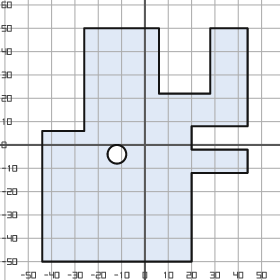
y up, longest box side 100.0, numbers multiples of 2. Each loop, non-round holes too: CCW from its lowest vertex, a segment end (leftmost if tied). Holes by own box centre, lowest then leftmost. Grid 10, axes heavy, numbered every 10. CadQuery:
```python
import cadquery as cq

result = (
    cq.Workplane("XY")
    .moveTo(-44.0, -50.0)
    .lineTo(20.0, -50.0)
    .lineTo(20.0, -12.0)
    .lineTo(44.0, -12.0)
    .lineTo(44.0, -2.0)
    .lineTo(20.0, -2.0)
    .lineTo(20.0, 8.0)
    .lineTo(44.0, 8.0)
    .lineTo(44.0, 50.0)
    .lineTo(28.0, 50.0)
    .lineTo(28.0, 22.0)
    .lineTo(6.0, 22.0)
    .lineTo(6.0, 50.0)
    .lineTo(-26.0, 50.0)
    .lineTo(-26.0, 6.0)
    .lineTo(-44.0, 6.0)
    .close()
    .moveTo(-12.0, -4.0)
    .circle(4.0)
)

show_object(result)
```